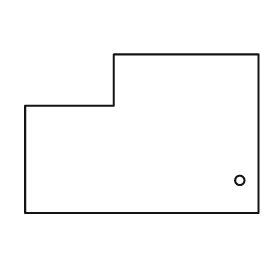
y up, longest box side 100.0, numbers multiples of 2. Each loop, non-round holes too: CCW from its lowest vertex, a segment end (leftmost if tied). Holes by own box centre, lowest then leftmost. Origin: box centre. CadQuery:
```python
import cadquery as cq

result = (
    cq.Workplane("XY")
    .moveTo(-50.0, -34.0)
    .lineTo(50.0, -34.0)
    .lineTo(50.0, 34.0)
    .lineTo(-12.0, 34.0)
    .lineTo(-12.0, 12.0)
    .lineTo(-50.0, 12.0)
    .close()
    .moveTo(42.0, -20.0)
    .circle(2.0)
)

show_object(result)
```